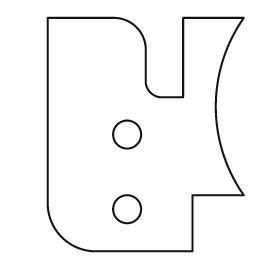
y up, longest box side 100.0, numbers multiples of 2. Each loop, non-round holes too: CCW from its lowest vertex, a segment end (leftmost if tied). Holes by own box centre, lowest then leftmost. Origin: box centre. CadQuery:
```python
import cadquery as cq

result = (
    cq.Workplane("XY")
    .moveTo(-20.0, -50.0)
    .lineTo(20.0, -50.0)
    .lineTo(20.0, -26.0)
    .lineTo(42.0, -26.0)
    .threePointArc((30.0, 12.0), (42.0, 50.0))
    .lineTo(16.0, 50.0)
    .lineTo(16.0, 16.0)
    .lineTo(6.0, 16.0)
    .threePointArc((2.0, 18.0), (0.0, 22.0))
    .lineTo(0.0, 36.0)
    .threePointArc((-4.0, 46.0), (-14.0, 50.0))
    .lineTo(-42.0, 50.0)
    .lineTo(-42.0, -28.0)
    .threePointArc((-36.0, -44.0), (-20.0, -50.0))
    .close()
    .moveTo(-8.0, -32.0)
    .circle(6.0)
    .moveTo(-8.0, 0.0)
    .circle(6.0)
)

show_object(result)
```